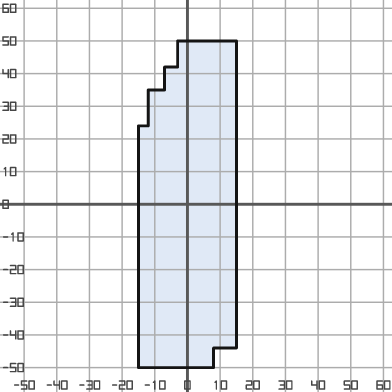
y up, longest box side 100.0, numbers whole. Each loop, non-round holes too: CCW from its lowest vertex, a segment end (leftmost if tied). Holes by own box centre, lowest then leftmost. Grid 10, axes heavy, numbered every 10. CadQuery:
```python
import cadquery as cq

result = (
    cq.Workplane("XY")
    .moveTo(-15.0, -50.0)
    .lineTo(8.0, -50.0)
    .lineTo(8.0, -44.0)
    .lineTo(15.0, -44.0)
    .lineTo(15.0, 50.0)
    .lineTo(-3.0, 50.0)
    .lineTo(-3.0, 42.0)
    .lineTo(-7.0, 42.0)
    .lineTo(-7.0, 35.0)
    .lineTo(-12.0, 35.0)
    .lineTo(-12.0, 24.0)
    .lineTo(-15.0, 24.0)
    .close()
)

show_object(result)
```